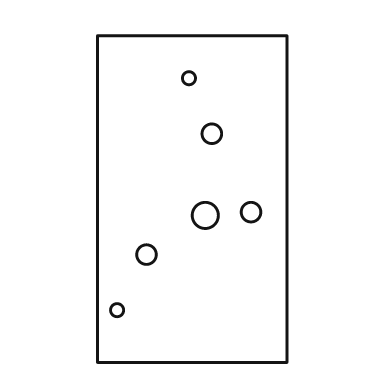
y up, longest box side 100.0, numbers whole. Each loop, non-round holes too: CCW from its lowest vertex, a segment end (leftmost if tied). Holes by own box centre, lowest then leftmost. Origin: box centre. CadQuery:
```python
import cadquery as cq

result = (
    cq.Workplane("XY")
    .moveTo(-29.0, -50.0)
    .lineTo(29.0, -50.0)
    .lineTo(29.0, 50.0)
    .lineTo(-29.0, 50.0)
    .close()
    .moveTo(-23.0, -34.0)
    .circle(2.0)
    .moveTo(-14.0, -17.0)
    .circle(3.0)
    .moveTo(4.0, -5.0)
    .circle(4.0)
    .moveTo(18.0, -4.0)
    .circle(3.0)
    .moveTo(6.0, 20.0)
    .circle(3.0)
    .moveTo(-1.0, 37.0)
    .circle(2.0)
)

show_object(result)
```